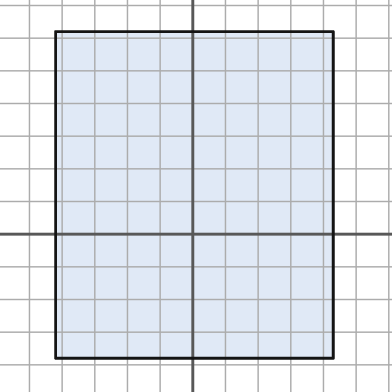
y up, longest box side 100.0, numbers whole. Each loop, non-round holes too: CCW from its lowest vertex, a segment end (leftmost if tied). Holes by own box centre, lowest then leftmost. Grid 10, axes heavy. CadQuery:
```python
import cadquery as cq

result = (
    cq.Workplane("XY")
    .moveTo(-42.0, -38.0)
    .lineTo(43.0, -38.0)
    .lineTo(43.0, 62.0)
    .lineTo(-42.0, 62.0)
    .close()
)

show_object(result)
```